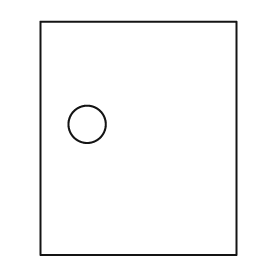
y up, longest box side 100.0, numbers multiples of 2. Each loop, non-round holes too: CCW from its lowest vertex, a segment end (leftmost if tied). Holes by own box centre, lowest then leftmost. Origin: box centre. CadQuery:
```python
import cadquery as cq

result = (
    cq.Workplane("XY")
    .moveTo(-42.0, -50.0)
    .lineTo(42.0, -50.0)
    .lineTo(42.0, 50.0)
    .lineTo(-42.0, 50.0)
    .close()
    .moveTo(-22.0, 6.0)
    .circle(8.0)
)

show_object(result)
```